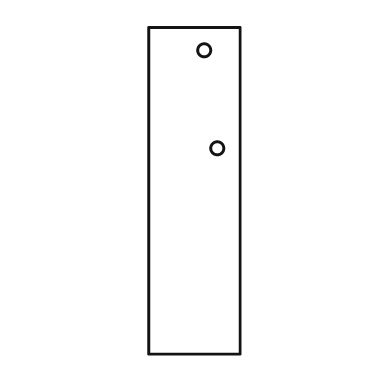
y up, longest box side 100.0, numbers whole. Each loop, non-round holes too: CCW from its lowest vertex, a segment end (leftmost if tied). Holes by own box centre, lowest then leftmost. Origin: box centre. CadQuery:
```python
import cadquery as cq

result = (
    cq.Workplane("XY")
    .moveTo(-14.0, -50.0)
    .lineTo(14.0, -50.0)
    .lineTo(14.0, 50.0)
    .lineTo(-14.0, 50.0)
    .close()
    .moveTo(7.0, 13.0)
    .circle(2.0)
    .moveTo(3.0, 43.0)
    .circle(2.0)
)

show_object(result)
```